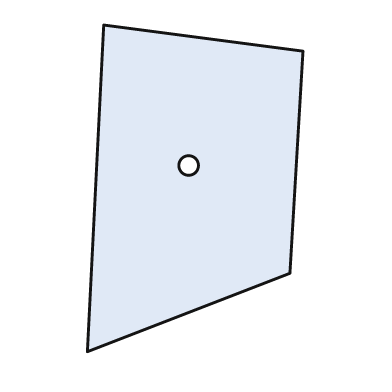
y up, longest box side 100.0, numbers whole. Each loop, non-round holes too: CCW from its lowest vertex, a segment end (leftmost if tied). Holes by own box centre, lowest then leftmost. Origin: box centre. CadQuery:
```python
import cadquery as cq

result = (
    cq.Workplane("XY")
    .moveTo(-33.0, -50.0)
    .lineTo(29.0, -26.0)
    .lineTo(33.0, 42.0)
    .lineTo(-28.0, 50.0)
    .close()
    .moveTo(-2.0, 7.0)
    .circle(3.0)
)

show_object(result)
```